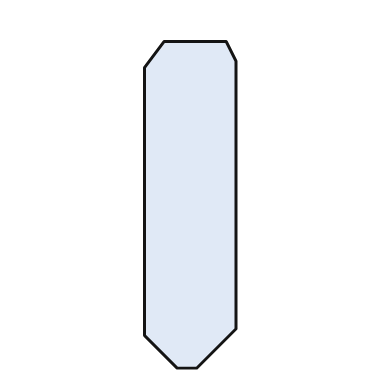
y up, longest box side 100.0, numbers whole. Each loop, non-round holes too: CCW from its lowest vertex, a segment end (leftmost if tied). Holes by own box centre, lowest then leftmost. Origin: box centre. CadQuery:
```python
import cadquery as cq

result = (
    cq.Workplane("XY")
    .moveTo(-4.0, -50.0)
    .lineTo(2.0, -50.0)
    .lineTo(14.0, -38.0)
    .lineTo(14.0, 44.0)
    .lineTo(11.0, 50.0)
    .lineTo(-8.0, 50.0)
    .lineTo(-14.0, 42.0)
    .lineTo(-14.0, -40.0)
    .close()
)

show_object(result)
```